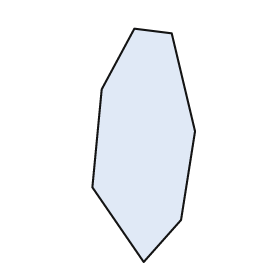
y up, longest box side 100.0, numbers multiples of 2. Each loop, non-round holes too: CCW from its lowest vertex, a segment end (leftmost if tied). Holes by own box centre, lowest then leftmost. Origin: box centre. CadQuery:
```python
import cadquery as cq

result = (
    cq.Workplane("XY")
    .moveTo(0.0, -50.0)
    .lineTo(16.0, -32.0)
    .lineTo(22.0, 6.0)
    .lineTo(12.0, 48.0)
    .lineTo(-4.0, 50.0)
    .lineTo(-18.0, 24.0)
    .lineTo(-22.0, -18.0)
    .close()
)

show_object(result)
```